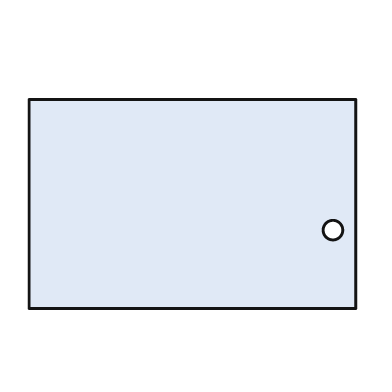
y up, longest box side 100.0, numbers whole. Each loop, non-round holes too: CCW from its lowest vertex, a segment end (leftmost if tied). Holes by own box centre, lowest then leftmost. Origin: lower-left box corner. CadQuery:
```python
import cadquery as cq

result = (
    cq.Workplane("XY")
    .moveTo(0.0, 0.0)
    .lineTo(100.0, 0.0)
    .lineTo(100.0, 64.0)
    .lineTo(0.0, 64.0)
    .close()
    .moveTo(93.0, 24.0)
    .circle(3.0)
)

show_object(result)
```